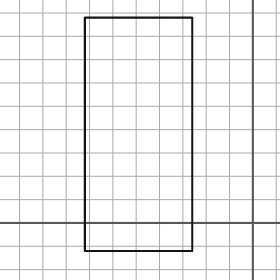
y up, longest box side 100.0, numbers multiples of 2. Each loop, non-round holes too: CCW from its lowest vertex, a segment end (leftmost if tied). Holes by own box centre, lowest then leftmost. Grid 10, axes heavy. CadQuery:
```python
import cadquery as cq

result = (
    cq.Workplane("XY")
    .moveTo(-72.0, -12.0)
    .lineTo(-26.0, -12.0)
    .lineTo(-26.0, 88.0)
    .lineTo(-72.0, 88.0)
    .close()
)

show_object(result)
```